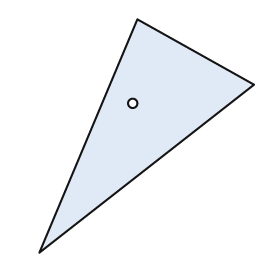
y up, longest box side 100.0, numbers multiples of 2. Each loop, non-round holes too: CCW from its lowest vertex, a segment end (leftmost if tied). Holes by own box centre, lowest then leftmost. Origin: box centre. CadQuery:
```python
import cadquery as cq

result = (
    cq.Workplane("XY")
    .moveTo(-46.0, -50.0)
    .lineTo(46.0, 22.0)
    .lineTo(-4.0, 50.0)
    .close()
    .moveTo(-6.0, 14.0)
    .circle(2.0)
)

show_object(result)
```